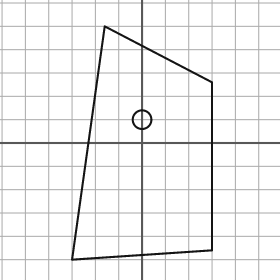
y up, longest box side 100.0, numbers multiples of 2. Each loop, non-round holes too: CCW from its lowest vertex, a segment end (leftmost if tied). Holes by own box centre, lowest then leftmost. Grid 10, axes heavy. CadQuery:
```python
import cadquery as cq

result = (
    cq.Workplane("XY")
    .moveTo(-30.0, -50.0)
    .lineTo(30.0, -46.0)
    .lineTo(30.0, 26.0)
    .lineTo(-16.0, 50.0)
    .close()
    .moveTo(0.0, 10.0)
    .circle(4.0)
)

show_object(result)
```